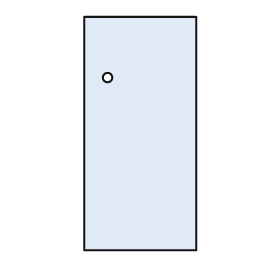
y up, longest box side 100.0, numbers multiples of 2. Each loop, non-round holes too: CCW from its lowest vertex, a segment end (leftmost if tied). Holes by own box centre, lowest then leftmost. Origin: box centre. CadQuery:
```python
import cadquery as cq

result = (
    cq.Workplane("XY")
    .moveTo(-24.0, -50.0)
    .lineTo(24.0, -50.0)
    .lineTo(24.0, 50.0)
    .lineTo(-24.0, 50.0)
    .close()
    .moveTo(-14.0, 24.0)
    .circle(2.0)
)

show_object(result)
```